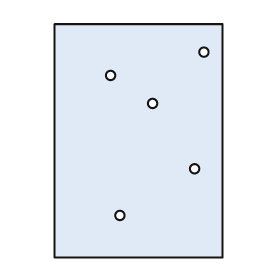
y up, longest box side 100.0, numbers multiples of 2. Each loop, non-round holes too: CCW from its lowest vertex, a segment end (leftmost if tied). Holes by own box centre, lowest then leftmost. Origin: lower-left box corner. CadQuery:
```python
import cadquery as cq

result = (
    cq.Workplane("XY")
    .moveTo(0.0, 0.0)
    .lineTo(72.0, 0.0)
    .lineTo(72.0, 100.0)
    .lineTo(0.0, 100.0)
    .close()
    .moveTo(28.0, 18.0)
    .circle(2.0)
    .moveTo(60.0, 38.0)
    .circle(2.0)
    .moveTo(42.0, 66.0)
    .circle(2.0)
    .moveTo(24.0, 78.0)
    .circle(2.0)
    .moveTo(64.0, 88.0)
    .circle(2.0)
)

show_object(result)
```